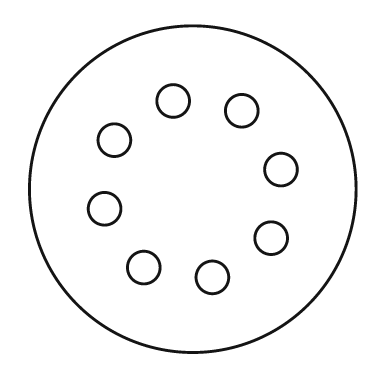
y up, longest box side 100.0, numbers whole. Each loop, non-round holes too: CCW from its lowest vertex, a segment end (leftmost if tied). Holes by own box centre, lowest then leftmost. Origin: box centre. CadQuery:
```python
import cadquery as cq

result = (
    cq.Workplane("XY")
    .moveTo(0.0, 0.0)
    .circle(50.0)
    .moveTo(6.0, -27.0)
    .circle(5.0)
    .moveTo(-15.0, -24.0)
    .circle(5.0)
    .moveTo(24.0, -15.0)
    .circle(5.0)
    .moveTo(-27.0, -6.0)
    .circle(5.0)
    .moveTo(27.0, 6.0)
    .circle(5.0)
    .moveTo(-24.0, 15.0)
    .circle(5.0)
    .moveTo(15.0, 24.0)
    .circle(5.0)
    .moveTo(-6.0, 27.0)
    .circle(5.0)
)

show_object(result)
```